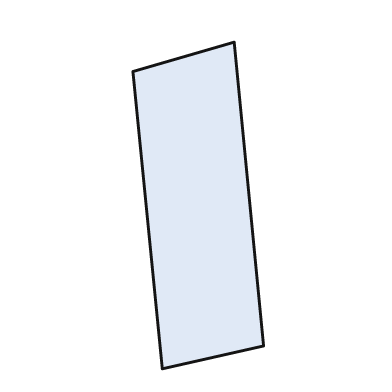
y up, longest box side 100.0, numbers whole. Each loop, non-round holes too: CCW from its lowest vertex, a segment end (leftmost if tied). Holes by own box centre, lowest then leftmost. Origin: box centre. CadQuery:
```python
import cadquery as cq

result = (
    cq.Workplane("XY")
    .moveTo(-11.0, -50.0)
    .lineTo(20.0, -43.0)
    .lineTo(11.0, 50.0)
    .lineTo(-20.0, 41.0)
    .close()
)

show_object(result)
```